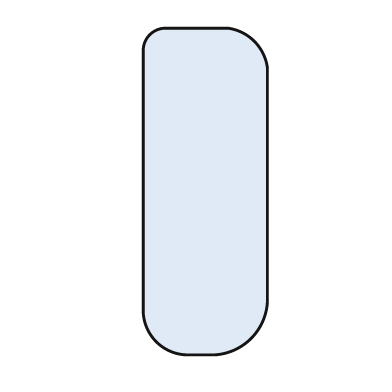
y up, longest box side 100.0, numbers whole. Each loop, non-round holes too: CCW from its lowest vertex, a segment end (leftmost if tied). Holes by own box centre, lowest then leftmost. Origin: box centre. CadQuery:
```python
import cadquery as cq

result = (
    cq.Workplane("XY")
    .moveTo(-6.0, -50.0)
    .lineTo(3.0, -50.0)
    .threePointArc((14.0, -45.0), (19.0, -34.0))
    .lineTo(19.0, 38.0)
    .threePointArc((15.0, 46.0), (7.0, 50.0))
    .lineTo(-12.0, 50.0)
    .threePointArc((-17.0, 48.0), (-19.0, 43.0))
    .lineTo(-19.0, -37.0)
    .threePointArc((-15.0, -46.0), (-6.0, -50.0))
    .close()
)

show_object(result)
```